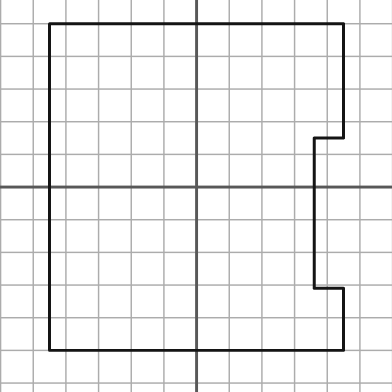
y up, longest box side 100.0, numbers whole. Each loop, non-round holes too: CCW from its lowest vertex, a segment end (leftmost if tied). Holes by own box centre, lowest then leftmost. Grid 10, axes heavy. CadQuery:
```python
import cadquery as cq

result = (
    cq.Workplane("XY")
    .moveTo(-45.0, -50.0)
    .lineTo(45.0, -50.0)
    .lineTo(45.0, -31.0)
    .lineTo(36.0, -31.0)
    .lineTo(36.0, 15.0)
    .lineTo(45.0, 15.0)
    .lineTo(45.0, 50.0)
    .lineTo(-45.0, 50.0)
    .close()
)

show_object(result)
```